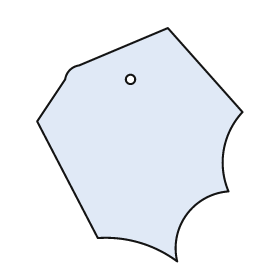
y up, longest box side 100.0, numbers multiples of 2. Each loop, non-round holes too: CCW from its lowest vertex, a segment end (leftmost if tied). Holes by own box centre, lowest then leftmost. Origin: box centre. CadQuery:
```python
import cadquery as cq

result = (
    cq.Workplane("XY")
    .moveTo(16.0, -50.0)
    .threePointArc((20.0, -30.0), (38.0, -20.0))
    .threePointArc((36.0, -2.0), (44.0, 14.0))
    .lineTo(12.0, 50.0)
    .lineTo(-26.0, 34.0)
    .threePointArc((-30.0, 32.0), (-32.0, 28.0))
    .lineTo(-44.0, 10.0)
    .lineTo(-18.0, -40.0)
    .threePointArc((0.0, -42.0), (16.0, -50.0))
    .close()
    .moveTo(-4.0, 28.0)
    .circle(2.0)
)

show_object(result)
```